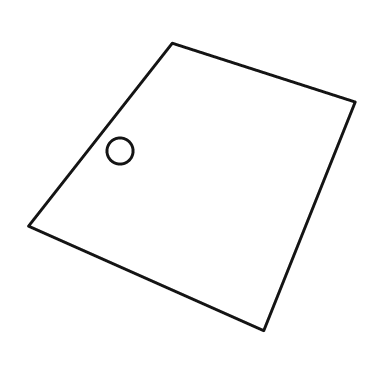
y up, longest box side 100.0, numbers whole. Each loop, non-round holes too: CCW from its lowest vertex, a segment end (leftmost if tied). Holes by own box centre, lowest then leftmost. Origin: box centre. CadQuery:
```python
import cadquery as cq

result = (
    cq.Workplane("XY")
    .moveTo(22.0, -44.0)
    .lineTo(50.0, 26.0)
    .lineTo(-6.0, 44.0)
    .lineTo(-50.0, -12.0)
    .close()
    .moveTo(-22.0, 11.0)
    .circle(4.0)
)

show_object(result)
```